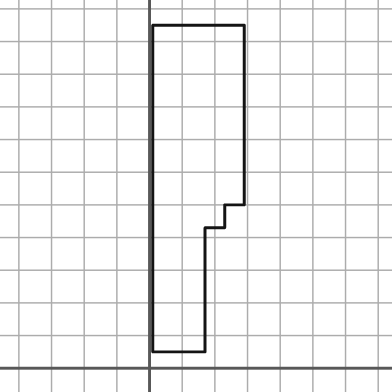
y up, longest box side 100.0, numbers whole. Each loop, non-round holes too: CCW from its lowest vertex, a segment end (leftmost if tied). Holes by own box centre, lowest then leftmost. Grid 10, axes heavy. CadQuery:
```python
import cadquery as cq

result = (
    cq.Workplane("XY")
    .moveTo(1.0, 5.0)
    .lineTo(17.0, 5.0)
    .lineTo(17.0, 43.0)
    .lineTo(23.0, 43.0)
    .lineTo(23.0, 50.0)
    .lineTo(29.0, 50.0)
    .lineTo(29.0, 105.0)
    .lineTo(1.0, 105.0)
    .close()
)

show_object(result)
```